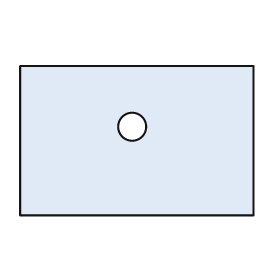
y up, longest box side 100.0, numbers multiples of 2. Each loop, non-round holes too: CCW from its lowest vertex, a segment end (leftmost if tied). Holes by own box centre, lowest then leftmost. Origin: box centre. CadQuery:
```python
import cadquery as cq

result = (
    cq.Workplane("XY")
    .moveTo(-50.0, -32.0)
    .lineTo(50.0, -32.0)
    .lineTo(50.0, 32.0)
    .lineTo(-50.0, 32.0)
    .close()
    .moveTo(-2.0, 6.0)
    .circle(6.0)
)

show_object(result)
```